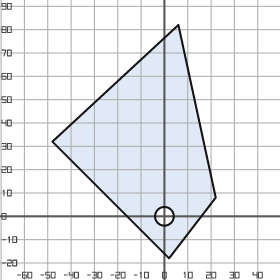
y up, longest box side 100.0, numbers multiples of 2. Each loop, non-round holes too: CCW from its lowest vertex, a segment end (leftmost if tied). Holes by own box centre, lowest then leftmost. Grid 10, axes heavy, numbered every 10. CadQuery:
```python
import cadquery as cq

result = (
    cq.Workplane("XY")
    .moveTo(2.0, -18.0)
    .lineTo(22.0, 8.0)
    .lineTo(6.0, 82.0)
    .lineTo(-48.0, 32.0)
    .close()
    .moveTo(0.0, 0.0)
    .circle(4.0)
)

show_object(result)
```